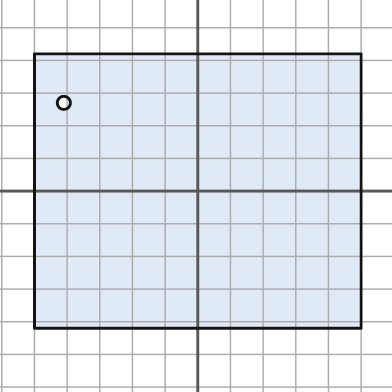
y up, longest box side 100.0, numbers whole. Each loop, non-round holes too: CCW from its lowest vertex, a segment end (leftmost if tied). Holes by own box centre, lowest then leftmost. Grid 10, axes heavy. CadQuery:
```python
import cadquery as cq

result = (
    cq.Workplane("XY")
    .moveTo(-50.0, -42.0)
    .lineTo(50.0, -42.0)
    .lineTo(50.0, 42.0)
    .lineTo(-50.0, 42.0)
    .close()
    .moveTo(-41.0, 27.0)
    .circle(2.0)
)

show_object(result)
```